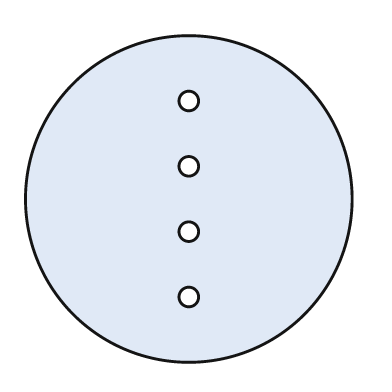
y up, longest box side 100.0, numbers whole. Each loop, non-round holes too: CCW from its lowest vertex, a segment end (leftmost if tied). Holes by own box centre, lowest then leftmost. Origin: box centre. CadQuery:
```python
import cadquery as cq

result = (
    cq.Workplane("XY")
    .moveTo(0.0, 0.0)
    .circle(50.0)
    .moveTo(0.0, -30.0)
    .circle(3.0)
    .moveTo(0.0, -10.0)
    .circle(3.0)
    .moveTo(0.0, 10.0)
    .circle(3.0)
    .moveTo(0.0, 30.0)
    .circle(3.0)
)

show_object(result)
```